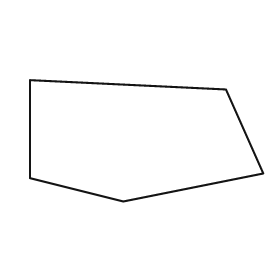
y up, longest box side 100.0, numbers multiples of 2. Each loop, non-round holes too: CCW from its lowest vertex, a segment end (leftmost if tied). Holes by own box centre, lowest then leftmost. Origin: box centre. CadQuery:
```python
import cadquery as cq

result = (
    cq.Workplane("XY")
    .moveTo(-10.0, -26.0)
    .lineTo(50.0, -14.0)
    .lineTo(34.0, 22.0)
    .lineTo(-50.0, 26.0)
    .lineTo(-50.0, -16.0)
    .close()
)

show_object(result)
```